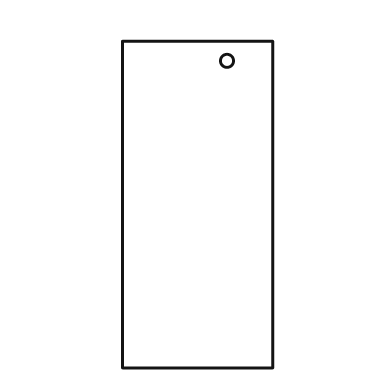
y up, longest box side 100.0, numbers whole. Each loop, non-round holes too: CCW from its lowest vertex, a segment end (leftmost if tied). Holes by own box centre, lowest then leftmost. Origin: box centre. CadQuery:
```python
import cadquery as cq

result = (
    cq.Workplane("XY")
    .moveTo(-23.0, -50.0)
    .lineTo(23.0, -50.0)
    .lineTo(23.0, 50.0)
    .lineTo(-23.0, 50.0)
    .close()
    .moveTo(9.0, 44.0)
    .circle(2.0)
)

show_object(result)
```